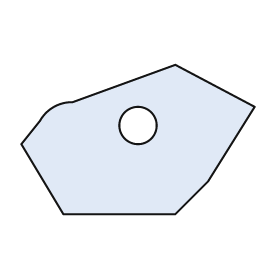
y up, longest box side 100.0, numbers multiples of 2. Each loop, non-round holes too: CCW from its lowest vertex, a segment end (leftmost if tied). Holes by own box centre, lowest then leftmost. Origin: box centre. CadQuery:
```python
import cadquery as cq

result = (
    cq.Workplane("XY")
    .moveTo(-32.0, -32.0)
    .lineTo(16.0, -32.0)
    .lineTo(30.0, -18.0)
    .lineTo(50.0, 14.0)
    .lineTo(16.0, 32.0)
    .lineTo(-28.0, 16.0)
    .threePointArc((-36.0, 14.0), (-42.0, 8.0))
    .lineTo(-50.0, -2.0)
    .close()
    .moveTo(0.0, 6.0)
    .circle(8.0)
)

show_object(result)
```